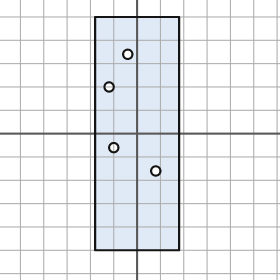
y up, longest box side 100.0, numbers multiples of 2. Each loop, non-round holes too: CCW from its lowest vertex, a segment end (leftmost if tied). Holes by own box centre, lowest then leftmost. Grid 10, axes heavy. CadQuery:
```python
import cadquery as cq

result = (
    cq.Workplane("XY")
    .moveTo(-18.0, -50.0)
    .lineTo(18.0, -50.0)
    .lineTo(18.0, 50.0)
    .lineTo(-18.0, 50.0)
    .close()
    .moveTo(8.0, -16.0)
    .circle(2.0)
    .moveTo(-10.0, -6.0)
    .circle(2.0)
    .moveTo(-12.0, 20.0)
    .circle(2.0)
    .moveTo(-4.0, 34.0)
    .circle(2.0)
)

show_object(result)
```